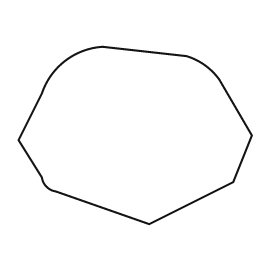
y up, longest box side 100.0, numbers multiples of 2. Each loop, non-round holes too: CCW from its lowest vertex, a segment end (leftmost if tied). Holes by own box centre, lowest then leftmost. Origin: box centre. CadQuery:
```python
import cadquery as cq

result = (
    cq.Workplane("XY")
    .moveTo(6.0, -38.0)
    .lineTo(42.0, -20.0)
    .lineTo(50.0, 0.0)
    .lineTo(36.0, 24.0)
    .threePointArc((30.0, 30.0), (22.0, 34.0))
    .lineTo(-14.0, 38.0)
    .threePointArc((-30.0, 32.0), (-40.0, 18.0))
    .lineTo(-50.0, -2.0)
    .lineTo(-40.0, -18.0)
    .threePointArc((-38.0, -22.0), (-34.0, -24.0))
    .close()
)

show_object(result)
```